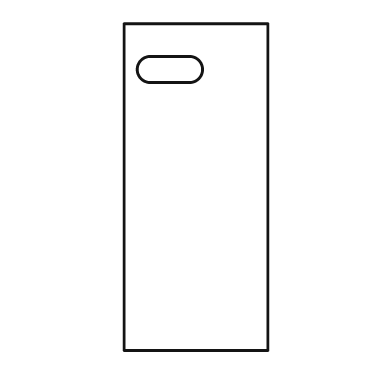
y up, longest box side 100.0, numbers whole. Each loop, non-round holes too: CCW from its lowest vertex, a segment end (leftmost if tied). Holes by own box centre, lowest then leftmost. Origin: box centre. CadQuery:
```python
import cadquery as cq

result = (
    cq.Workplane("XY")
    .moveTo(-22.0, -50.0)
    .lineTo(22.0, -50.0)
    .lineTo(22.0, 50.0)
    .lineTo(-22.0, 50.0)
    .close()
    .moveTo(-14.0, 32.0)
    .lineTo(-2.0, 32.0)
    .threePointArc((2.0, 36.0), (-2.0, 40.0))
    .lineTo(-14.0, 40.0)
    .threePointArc((-18.0, 36.0), (-14.0, 32.0))
    .close()
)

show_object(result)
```